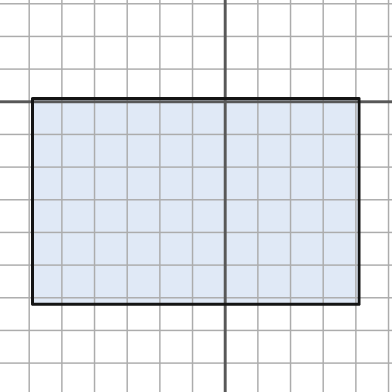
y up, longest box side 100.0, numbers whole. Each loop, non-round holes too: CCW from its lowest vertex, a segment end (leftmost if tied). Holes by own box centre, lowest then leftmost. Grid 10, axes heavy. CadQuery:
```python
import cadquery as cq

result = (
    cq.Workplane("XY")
    .moveTo(-59.0, -62.0)
    .lineTo(41.0, -62.0)
    .lineTo(41.0, 1.0)
    .lineTo(-59.0, 1.0)
    .close()
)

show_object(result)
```